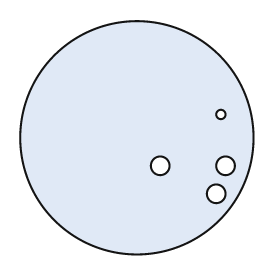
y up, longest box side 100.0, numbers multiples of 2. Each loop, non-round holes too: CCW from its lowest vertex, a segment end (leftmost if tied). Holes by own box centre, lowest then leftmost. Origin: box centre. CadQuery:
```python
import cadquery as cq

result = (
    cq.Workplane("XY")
    .moveTo(0.0, 0.0)
    .circle(50.0)
    .moveTo(34.0, -24.0)
    .circle(4.0)
    .moveTo(10.0, -12.0)
    .circle(4.0)
    .moveTo(38.0, -12.0)
    .circle(4.0)
    .moveTo(36.0, 10.0)
    .circle(2.0)
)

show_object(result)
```